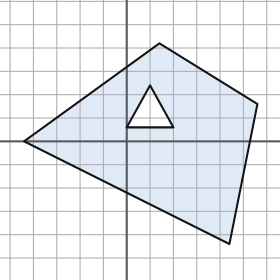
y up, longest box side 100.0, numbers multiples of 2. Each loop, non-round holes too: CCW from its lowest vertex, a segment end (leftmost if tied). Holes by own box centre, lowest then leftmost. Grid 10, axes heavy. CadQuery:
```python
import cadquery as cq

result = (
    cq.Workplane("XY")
    .moveTo(44.0, -44.0)
    .lineTo(56.0, 16.0)
    .lineTo(14.0, 42.0)
    .lineTo(-44.0, 0.0)
    .close()
    .moveTo(0.0, 6.0)
    .lineTo(20.0, 6.0)
    .lineTo(10.0, 24.0)
    .close()
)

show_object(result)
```